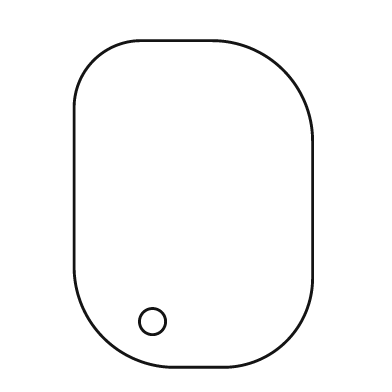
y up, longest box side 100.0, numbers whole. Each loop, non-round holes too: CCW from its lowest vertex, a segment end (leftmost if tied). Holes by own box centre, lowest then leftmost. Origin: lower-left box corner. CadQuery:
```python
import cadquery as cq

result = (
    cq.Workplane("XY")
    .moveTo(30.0, 0.0)
    .lineTo(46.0, 0.0)
    .threePointArc((65.0, 8.0), (73.0, 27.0))
    .lineTo(73.0, 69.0)
    .threePointArc((64.0, 91.0), (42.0, 100.0))
    .lineTo(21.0, 100.0)
    .threePointArc((6.0, 94.0), (0.0, 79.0))
    .lineTo(0.0, 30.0)
    .threePointArc((9.0, 9.0), (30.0, 0.0))
    .close()
    .moveTo(24.0, 14.0)
    .circle(4.0)
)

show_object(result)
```